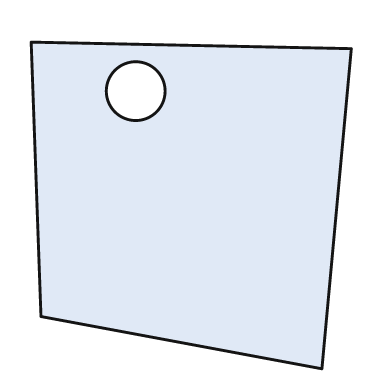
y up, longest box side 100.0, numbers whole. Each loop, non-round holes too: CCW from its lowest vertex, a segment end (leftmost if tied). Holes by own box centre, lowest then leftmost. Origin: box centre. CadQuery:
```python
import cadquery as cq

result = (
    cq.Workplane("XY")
    .moveTo(40.0, -50.0)
    .lineTo(49.0, 48.0)
    .lineTo(-49.0, 50.0)
    .lineTo(-46.0, -34.0)
    .close()
    .moveTo(-17.0, 35.0)
    .circle(9.0)
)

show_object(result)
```